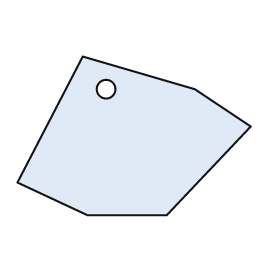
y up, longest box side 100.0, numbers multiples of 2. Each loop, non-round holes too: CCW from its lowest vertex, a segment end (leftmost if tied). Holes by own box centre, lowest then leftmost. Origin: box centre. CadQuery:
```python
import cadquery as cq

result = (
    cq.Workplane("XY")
    .moveTo(-20.0, -34.0)
    .lineTo(14.0, -34.0)
    .lineTo(50.0, 4.0)
    .lineTo(26.0, 20.0)
    .lineTo(-22.0, 34.0)
    .lineTo(-50.0, -20.0)
    .close()
    .moveTo(-12.0, 20.0)
    .circle(4.0)
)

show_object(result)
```